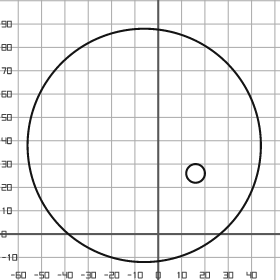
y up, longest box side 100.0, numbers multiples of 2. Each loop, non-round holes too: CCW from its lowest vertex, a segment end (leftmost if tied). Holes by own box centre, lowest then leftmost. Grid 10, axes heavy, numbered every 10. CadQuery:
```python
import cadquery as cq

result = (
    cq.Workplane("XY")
    .moveTo(-6.0, 38.0)
    .circle(50.0)
    .moveTo(16.0, 26.0)
    .circle(4.0)
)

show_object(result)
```